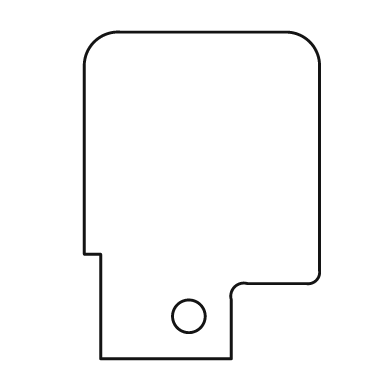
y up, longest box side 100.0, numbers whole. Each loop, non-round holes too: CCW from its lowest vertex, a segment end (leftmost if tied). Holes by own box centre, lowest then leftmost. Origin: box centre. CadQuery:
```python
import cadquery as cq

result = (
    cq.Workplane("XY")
    .moveTo(-31.0, -50.0)
    .lineTo(9.0, -50.0)
    .lineTo(9.0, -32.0)
    .threePointArc((10.0, -28.0), (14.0, -27.0))
    .lineTo(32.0, -27.0)
    .threePointArc((35.0, -26.0), (36.0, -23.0))
    .lineTo(36.0, 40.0)
    .threePointArc((33.0, 47.0), (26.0, 50.0))
    .lineTo(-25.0, 50.0)
    .threePointArc((-33.0, 47.0), (-36.0, 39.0))
    .lineTo(-36.0, -18.0)
    .lineTo(-31.0, -18.0)
    .close()
    .moveTo(-4.0, -37.0)
    .circle(5.0)
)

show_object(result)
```